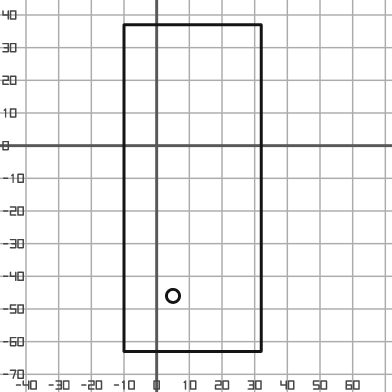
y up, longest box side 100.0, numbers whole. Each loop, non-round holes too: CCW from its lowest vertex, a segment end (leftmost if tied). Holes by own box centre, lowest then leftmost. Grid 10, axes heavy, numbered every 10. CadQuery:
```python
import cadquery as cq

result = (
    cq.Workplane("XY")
    .moveTo(-10.0, -63.0)
    .lineTo(32.0, -63.0)
    .lineTo(32.0, 37.0)
    .lineTo(-10.0, 37.0)
    .close()
    .moveTo(5.0, -46.0)
    .circle(2.0)
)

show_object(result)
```